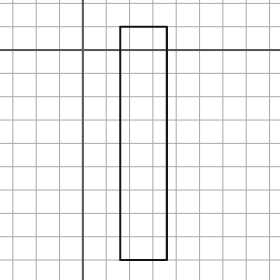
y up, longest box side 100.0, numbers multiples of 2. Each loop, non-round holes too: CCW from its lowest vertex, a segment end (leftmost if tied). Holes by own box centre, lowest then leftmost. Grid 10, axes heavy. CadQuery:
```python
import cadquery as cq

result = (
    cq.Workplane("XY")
    .moveTo(16.0, -90.0)
    .lineTo(36.0, -90.0)
    .lineTo(36.0, 10.0)
    .lineTo(16.0, 10.0)
    .close()
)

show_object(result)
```